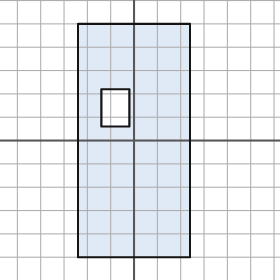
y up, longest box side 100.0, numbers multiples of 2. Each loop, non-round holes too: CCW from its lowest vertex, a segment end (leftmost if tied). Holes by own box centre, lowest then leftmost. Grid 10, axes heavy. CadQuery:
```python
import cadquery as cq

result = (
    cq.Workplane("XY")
    .moveTo(-24.0, -50.0)
    .lineTo(24.0, -50.0)
    .lineTo(24.0, 50.0)
    .lineTo(-24.0, 50.0)
    .close()
    .moveTo(-14.0, 6.0)
    .lineTo(-2.0, 6.0)
    .lineTo(-2.0, 22.0)
    .lineTo(-14.0, 22.0)
    .close()
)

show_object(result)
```